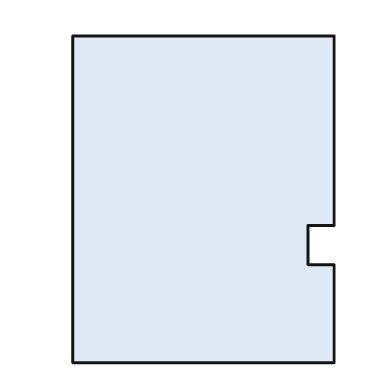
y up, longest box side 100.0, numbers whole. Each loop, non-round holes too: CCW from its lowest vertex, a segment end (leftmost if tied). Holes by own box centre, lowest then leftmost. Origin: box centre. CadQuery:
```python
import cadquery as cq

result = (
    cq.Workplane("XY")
    .moveTo(-40.0, -50.0)
    .lineTo(40.0, -50.0)
    .lineTo(40.0, -20.0)
    .lineTo(32.0, -20.0)
    .lineTo(32.0, -8.0)
    .lineTo(40.0, -8.0)
    .lineTo(40.0, 50.0)
    .lineTo(-40.0, 50.0)
    .close()
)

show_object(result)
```